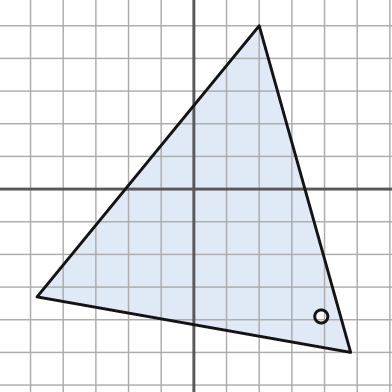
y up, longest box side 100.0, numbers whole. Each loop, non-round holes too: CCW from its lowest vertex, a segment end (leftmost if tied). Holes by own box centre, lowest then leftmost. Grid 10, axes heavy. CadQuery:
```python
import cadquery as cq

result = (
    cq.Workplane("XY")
    .moveTo(48.0, -50.0)
    .lineTo(20.0, 50.0)
    .lineTo(-48.0, -33.0)
    .close()
    .moveTo(39.0, -39.0)
    .circle(2.0)
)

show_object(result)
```